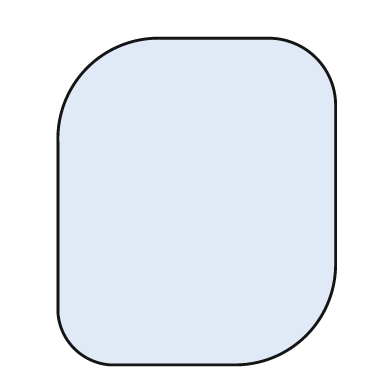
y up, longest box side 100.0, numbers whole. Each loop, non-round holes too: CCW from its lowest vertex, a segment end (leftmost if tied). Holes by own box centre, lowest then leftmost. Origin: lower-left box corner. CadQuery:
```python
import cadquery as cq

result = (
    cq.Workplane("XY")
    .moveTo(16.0, 0.0)
    .lineTo(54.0, 0.0)
    .threePointArc((76.0, 9.0), (85.0, 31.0))
    .lineTo(85.0, 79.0)
    .threePointArc((79.0, 94.0), (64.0, 100.0))
    .lineTo(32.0, 100.0)
    .threePointArc((9.0, 91.0), (0.0, 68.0))
    .lineTo(0.0, 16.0)
    .threePointArc((5.0, 5.0), (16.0, 0.0))
    .close()
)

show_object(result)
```